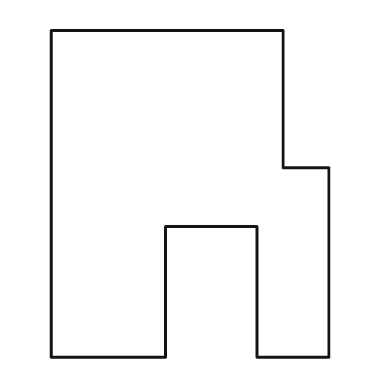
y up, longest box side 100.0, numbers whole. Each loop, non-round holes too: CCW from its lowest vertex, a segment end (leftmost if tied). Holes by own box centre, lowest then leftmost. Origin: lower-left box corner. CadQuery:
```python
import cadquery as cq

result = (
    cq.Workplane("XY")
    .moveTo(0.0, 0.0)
    .lineTo(35.0, 0.0)
    .lineTo(35.0, 40.0)
    .lineTo(63.0, 40.0)
    .lineTo(63.0, 0.0)
    .lineTo(85.0, 0.0)
    .lineTo(85.0, 58.0)
    .lineTo(71.0, 58.0)
    .lineTo(71.0, 100.0)
    .lineTo(0.0, 100.0)
    .close()
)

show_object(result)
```